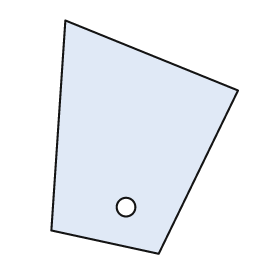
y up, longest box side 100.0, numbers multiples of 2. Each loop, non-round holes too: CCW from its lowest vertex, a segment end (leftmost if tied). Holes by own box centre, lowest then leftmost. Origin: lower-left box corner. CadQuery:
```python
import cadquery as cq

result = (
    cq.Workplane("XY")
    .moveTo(46.0, 0.0)
    .lineTo(80.0, 70.0)
    .lineTo(6.0, 100.0)
    .lineTo(0.0, 10.0)
    .close()
    .moveTo(32.0, 20.0)
    .circle(4.0)
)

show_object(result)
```